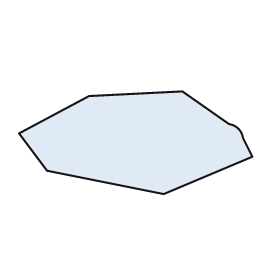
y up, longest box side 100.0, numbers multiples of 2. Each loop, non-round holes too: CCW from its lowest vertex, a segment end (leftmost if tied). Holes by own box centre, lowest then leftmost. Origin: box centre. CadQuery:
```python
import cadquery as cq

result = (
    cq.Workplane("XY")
    .moveTo(12.0, -22.0)
    .lineTo(50.0, -6.0)
    .lineTo(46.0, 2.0)
    .threePointArc((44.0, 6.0), (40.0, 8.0))
    .lineTo(20.0, 22.0)
    .lineTo(-20.0, 20.0)
    .lineTo(-50.0, 4.0)
    .lineTo(-38.0, -12.0)
    .close()
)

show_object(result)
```